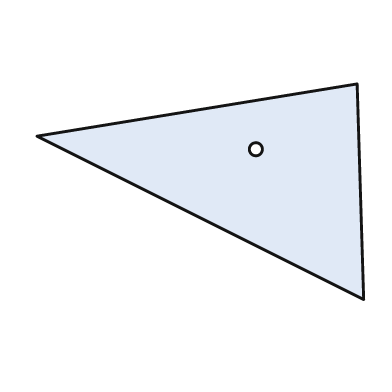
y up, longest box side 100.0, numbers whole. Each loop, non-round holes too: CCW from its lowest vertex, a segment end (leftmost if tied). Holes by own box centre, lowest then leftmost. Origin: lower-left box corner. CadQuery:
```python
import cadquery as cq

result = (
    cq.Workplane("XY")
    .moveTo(100.0, 0.0)
    .lineTo(98.0, 66.0)
    .lineTo(0.0, 50.0)
    .close()
    .moveTo(67.0, 46.0)
    .circle(2.0)
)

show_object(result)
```